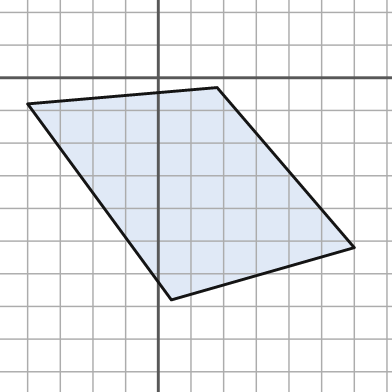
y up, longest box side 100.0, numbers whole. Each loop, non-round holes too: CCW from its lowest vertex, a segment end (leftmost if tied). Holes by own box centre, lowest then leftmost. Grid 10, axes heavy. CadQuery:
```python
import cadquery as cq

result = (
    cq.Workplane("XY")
    .moveTo(4.0, -68.0)
    .lineTo(60.0, -52.0)
    .lineTo(18.0, -3.0)
    .lineTo(-40.0, -8.0)
    .close()
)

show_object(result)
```